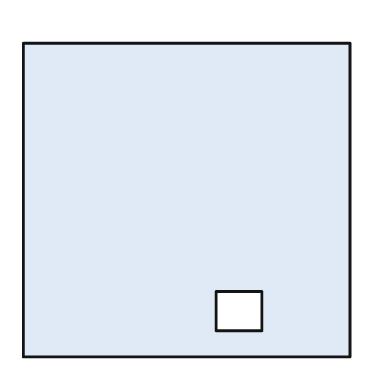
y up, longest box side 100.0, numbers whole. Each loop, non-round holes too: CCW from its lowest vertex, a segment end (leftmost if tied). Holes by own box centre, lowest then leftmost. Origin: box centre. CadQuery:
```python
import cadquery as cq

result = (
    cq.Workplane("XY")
    .moveTo(-50.0, -48.0)
    .lineTo(50.0, -48.0)
    .lineTo(50.0, 48.0)
    .lineTo(-50.0, 48.0)
    .close()
    .moveTo(9.0, -40.0)
    .lineTo(23.0, -40.0)
    .lineTo(23.0, -28.0)
    .lineTo(9.0, -28.0)
    .close()
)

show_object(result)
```